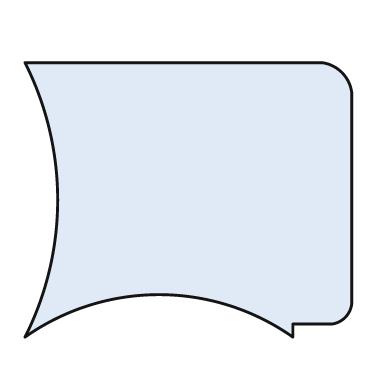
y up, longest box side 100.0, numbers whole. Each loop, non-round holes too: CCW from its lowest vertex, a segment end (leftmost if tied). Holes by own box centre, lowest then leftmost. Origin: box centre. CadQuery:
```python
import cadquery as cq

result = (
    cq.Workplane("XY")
    .moveTo(-50.0, -42.0)
    .threePointArc((-9.0, -29.0), (32.0, -42.0))
    .lineTo(32.0, -38.0)
    .lineTo(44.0, -38.0)
    .threePointArc((48.0, -36.0), (50.0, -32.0))
    .lineTo(50.0, 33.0)
    .threePointArc((47.0, 39.0), (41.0, 42.0))
    .lineTo(-50.0, 42.0)
    .threePointArc((-40.0, 0.0), (-50.0, -42.0))
    .close()
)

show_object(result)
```